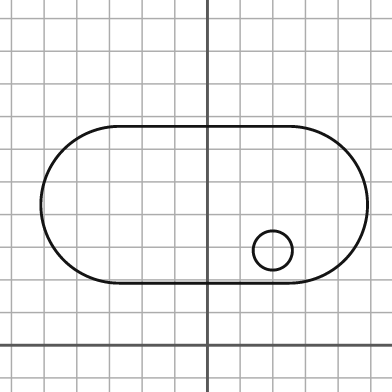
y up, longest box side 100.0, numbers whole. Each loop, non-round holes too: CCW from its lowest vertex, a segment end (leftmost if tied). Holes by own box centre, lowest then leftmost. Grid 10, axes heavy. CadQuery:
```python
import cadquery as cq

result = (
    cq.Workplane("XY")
    .moveTo(-27.0, 19.0)
    .lineTo(25.0, 19.0)
    .threePointArc((49.0, 43.0), (25.0, 67.0))
    .lineTo(-27.0, 67.0)
    .threePointArc((-51.0, 43.0), (-27.0, 19.0))
    .close()
    .moveTo(20.0, 29.0)
    .circle(6.0)
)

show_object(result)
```